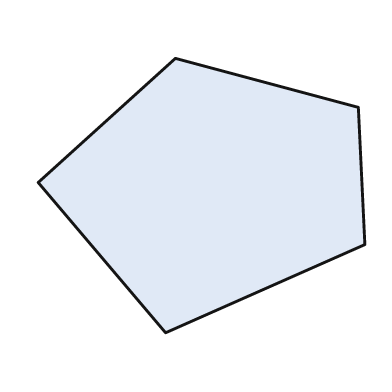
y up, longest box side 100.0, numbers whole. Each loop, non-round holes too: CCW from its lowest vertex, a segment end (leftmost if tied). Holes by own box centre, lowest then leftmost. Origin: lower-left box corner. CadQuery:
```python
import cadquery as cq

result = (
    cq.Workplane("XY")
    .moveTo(39.0, 0.0)
    .lineTo(100.0, 27.0)
    .lineTo(98.0, 69.0)
    .lineTo(42.0, 84.0)
    .lineTo(0.0, 46.0)
    .close()
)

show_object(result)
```